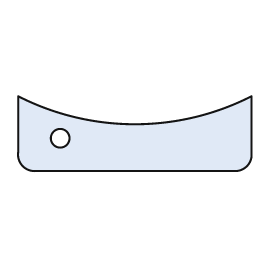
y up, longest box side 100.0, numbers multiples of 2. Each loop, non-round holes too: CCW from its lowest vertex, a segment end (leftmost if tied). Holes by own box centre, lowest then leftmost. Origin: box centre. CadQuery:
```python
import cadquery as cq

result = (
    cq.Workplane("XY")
    .moveTo(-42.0, -16.0)
    .lineTo(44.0, -16.0)
    .threePointArc((48.0, -14.0), (50.0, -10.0))
    .lineTo(50.0, 16.0)
    .threePointArc((0.0, 4.0), (-50.0, 16.0))
    .lineTo(-50.0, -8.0)
    .threePointArc((-48.0, -14.0), (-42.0, -16.0))
    .close()
    .moveTo(-32.0, -2.0)
    .circle(4.0)
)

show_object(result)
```